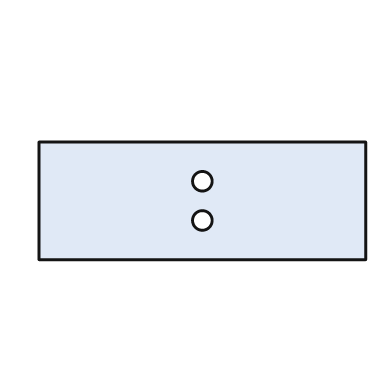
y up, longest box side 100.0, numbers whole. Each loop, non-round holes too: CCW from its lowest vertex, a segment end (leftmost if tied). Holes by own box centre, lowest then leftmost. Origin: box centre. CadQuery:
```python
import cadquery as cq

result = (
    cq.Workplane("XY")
    .moveTo(-50.0, -18.0)
    .lineTo(50.0, -18.0)
    .lineTo(50.0, 18.0)
    .lineTo(-50.0, 18.0)
    .close()
    .moveTo(0.0, -6.0)
    .circle(3.0)
    .moveTo(0.0, 6.0)
    .circle(3.0)
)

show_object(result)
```